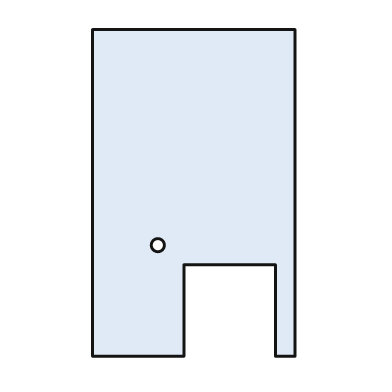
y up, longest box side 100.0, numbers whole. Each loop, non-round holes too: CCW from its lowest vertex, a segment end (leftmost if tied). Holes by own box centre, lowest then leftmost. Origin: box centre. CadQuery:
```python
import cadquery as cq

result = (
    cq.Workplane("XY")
    .moveTo(-31.0, -50.0)
    .lineTo(-3.0, -50.0)
    .lineTo(-3.0, -22.0)
    .lineTo(25.0, -22.0)
    .lineTo(25.0, -50.0)
    .lineTo(31.0, -50.0)
    .lineTo(31.0, 50.0)
    .lineTo(-31.0, 50.0)
    .close()
    .moveTo(-11.0, -16.0)
    .circle(2.0)
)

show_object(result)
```